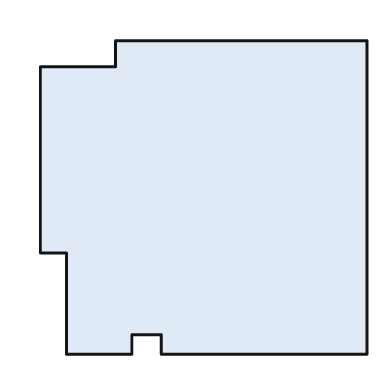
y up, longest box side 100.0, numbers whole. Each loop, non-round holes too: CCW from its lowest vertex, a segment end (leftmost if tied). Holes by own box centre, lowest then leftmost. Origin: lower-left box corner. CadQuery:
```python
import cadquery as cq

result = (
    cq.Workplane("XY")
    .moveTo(8.0, 0.0)
    .lineTo(28.0, 0.0)
    .lineTo(28.0, 6.0)
    .lineTo(37.0, 6.0)
    .lineTo(37.0, 0.0)
    .lineTo(100.0, 0.0)
    .lineTo(100.0, 96.0)
    .lineTo(23.0, 96.0)
    .lineTo(23.0, 88.0)
    .lineTo(0.0, 88.0)
    .lineTo(0.0, 31.0)
    .lineTo(8.0, 31.0)
    .close()
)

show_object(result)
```